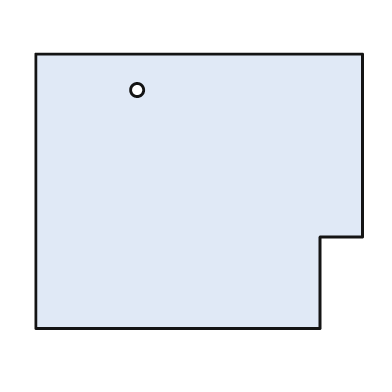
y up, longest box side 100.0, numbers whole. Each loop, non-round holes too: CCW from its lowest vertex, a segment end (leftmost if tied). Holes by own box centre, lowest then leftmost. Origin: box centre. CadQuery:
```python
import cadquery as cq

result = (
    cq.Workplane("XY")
    .moveTo(-50.0, -42.0)
    .lineTo(37.0, -42.0)
    .lineTo(37.0, -14.0)
    .lineTo(50.0, -14.0)
    .lineTo(50.0, 42.0)
    .lineTo(-50.0, 42.0)
    .close()
    .moveTo(-19.0, 31.0)
    .circle(2.0)
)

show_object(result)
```